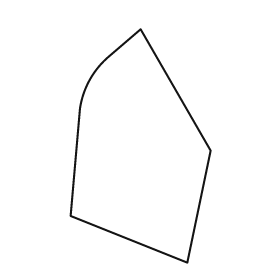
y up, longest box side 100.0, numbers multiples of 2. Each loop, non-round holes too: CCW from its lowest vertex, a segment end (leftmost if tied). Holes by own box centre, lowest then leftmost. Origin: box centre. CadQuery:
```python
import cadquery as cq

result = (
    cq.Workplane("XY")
    .moveTo(20.0, -50.0)
    .lineTo(30.0, -2.0)
    .lineTo(0.0, 50.0)
    .lineTo(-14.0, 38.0)
    .threePointArc((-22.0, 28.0), (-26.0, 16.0))
    .lineTo(-30.0, -30.0)
    .close()
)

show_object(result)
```